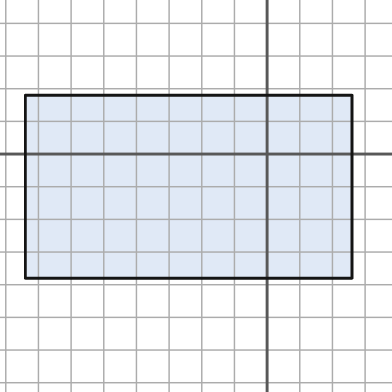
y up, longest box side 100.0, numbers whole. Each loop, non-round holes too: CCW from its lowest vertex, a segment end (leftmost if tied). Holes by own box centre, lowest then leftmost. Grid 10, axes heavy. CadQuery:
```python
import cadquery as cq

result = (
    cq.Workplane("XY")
    .moveTo(-74.0, -38.0)
    .lineTo(26.0, -38.0)
    .lineTo(26.0, 18.0)
    .lineTo(-74.0, 18.0)
    .close()
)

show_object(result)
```